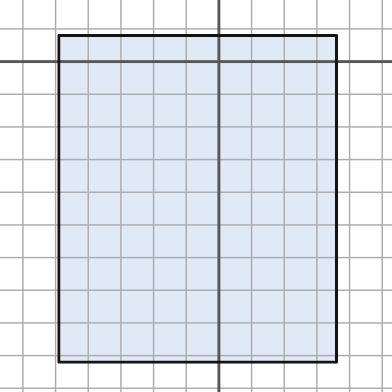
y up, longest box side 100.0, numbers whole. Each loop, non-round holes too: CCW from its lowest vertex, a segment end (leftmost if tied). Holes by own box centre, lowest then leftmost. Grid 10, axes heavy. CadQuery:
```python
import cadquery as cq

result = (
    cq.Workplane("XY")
    .moveTo(-49.0, -92.0)
    .lineTo(36.0, -92.0)
    .lineTo(36.0, 8.0)
    .lineTo(-49.0, 8.0)
    .close()
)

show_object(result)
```